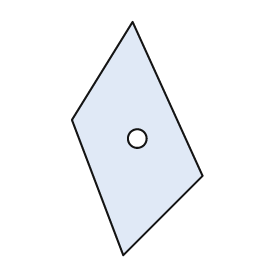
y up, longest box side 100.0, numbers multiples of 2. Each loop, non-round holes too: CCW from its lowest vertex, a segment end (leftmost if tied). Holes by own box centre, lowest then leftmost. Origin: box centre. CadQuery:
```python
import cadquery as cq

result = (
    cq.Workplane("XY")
    .moveTo(-6.0, -50.0)
    .lineTo(28.0, -16.0)
    .lineTo(-2.0, 50.0)
    .lineTo(-28.0, 8.0)
    .close()
    .moveTo(0.0, 0.0)
    .circle(4.0)
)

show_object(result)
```